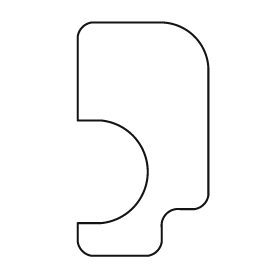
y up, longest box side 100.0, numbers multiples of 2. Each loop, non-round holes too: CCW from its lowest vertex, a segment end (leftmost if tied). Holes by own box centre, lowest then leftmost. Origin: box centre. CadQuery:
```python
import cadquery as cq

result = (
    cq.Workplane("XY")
    .moveTo(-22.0, -50.0)
    .lineTo(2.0, -50.0)
    .threePointArc((6.0, -48.0), (8.0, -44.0))
    .lineTo(8.0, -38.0)
    .threePointArc((10.0, -32.0), (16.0, -30.0))
    .lineTo(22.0, -30.0)
    .threePointArc((26.0, -28.0), (28.0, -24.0))
    .lineTo(28.0, 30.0)
    .threePointArc((22.0, 44.0), (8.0, 50.0))
    .lineTo(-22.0, 50.0)
    .threePointArc((-26.0, 48.0), (-28.0, 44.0))
    .lineTo(-28.0, 8.0)
    .lineTo(-18.0, 8.0)
    .threePointArc((2.0, -14.0), (-18.0, -36.0))
    .lineTo(-28.0, -36.0)
    .lineTo(-28.0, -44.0)
    .threePointArc((-26.0, -48.0), (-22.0, -50.0))
    .close()
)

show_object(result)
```